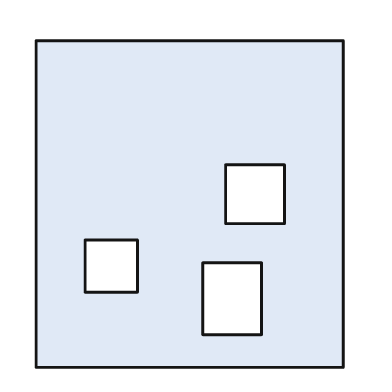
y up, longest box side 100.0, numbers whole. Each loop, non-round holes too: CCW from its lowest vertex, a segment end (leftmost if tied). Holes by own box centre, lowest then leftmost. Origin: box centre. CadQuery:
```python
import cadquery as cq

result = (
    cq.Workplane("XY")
    .moveTo(-47.0, -50.0)
    .lineTo(47.0, -50.0)
    .lineTo(47.0, 50.0)
    .lineTo(-47.0, 50.0)
    .close()
    .moveTo(4.0, -40.0)
    .lineTo(22.0, -40.0)
    .lineTo(22.0, -18.0)
    .lineTo(4.0, -18.0)
    .close()
    .moveTo(-32.0, -27.0)
    .lineTo(-16.0, -27.0)
    .lineTo(-16.0, -11.0)
    .lineTo(-32.0, -11.0)
    .close()
    .moveTo(11.0, -6.0)
    .lineTo(29.0, -6.0)
    .lineTo(29.0, 12.0)
    .lineTo(11.0, 12.0)
    .close()
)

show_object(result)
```